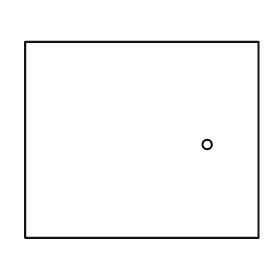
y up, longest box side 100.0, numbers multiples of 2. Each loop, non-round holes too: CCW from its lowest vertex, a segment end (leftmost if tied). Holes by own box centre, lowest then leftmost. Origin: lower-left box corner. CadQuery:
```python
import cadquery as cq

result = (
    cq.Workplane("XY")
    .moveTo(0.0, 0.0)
    .lineTo(100.0, 0.0)
    .lineTo(100.0, 84.0)
    .lineTo(0.0, 84.0)
    .close()
    .moveTo(78.0, 40.0)
    .circle(2.0)
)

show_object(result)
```